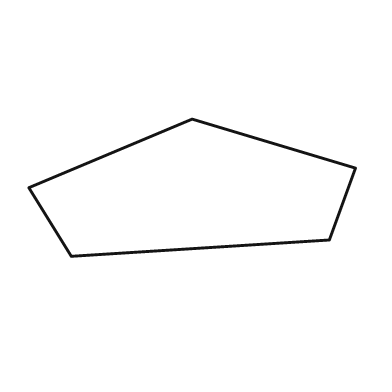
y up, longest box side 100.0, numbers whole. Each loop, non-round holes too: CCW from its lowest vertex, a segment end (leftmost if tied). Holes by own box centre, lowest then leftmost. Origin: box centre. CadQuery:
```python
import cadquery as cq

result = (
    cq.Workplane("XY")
    .moveTo(-37.0, -21.0)
    .lineTo(42.0, -16.0)
    .lineTo(50.0, 6.0)
    .lineTo(0.0, 21.0)
    .lineTo(-50.0, 0.0)
    .close()
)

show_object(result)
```